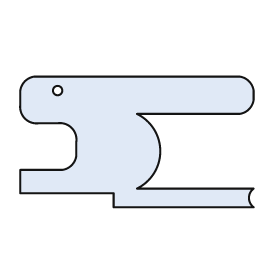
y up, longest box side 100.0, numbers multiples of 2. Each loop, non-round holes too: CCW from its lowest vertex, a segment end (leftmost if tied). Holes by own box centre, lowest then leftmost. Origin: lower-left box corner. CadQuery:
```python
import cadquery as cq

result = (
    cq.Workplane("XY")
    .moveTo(40.0, 0.0)
    .lineTo(100.0, 0.0)
    .threePointArc((98.0, 4.0), (100.0, 8.0))
    .lineTo(50.0, 8.0)
    .threePointArc((60.0, 24.0), (50.0, 40.0))
    .lineTo(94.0, 40.0)
    .threePointArc((98.0, 42.0), (100.0, 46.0))
    .lineTo(100.0, 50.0)
    .threePointArc((98.0, 54.0), (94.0, 56.0))
    .lineTo(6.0, 56.0)
    .threePointArc((2.0, 54.0), (0.0, 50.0))
    .lineTo(0.0, 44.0)
    .threePointArc((2.0, 38.0), (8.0, 36.0))
    .lineTo(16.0, 36.0)
    .threePointArc((22.0, 34.0), (24.0, 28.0))
    .lineTo(24.0, 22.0)
    .threePointArc((22.0, 18.0), (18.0, 16.0))
    .lineTo(0.0, 16.0)
    .lineTo(0.0, 6.0)
    .lineTo(40.0, 6.0)
    .close()
    .moveTo(16.0, 50.0)
    .circle(2.0)
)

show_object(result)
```